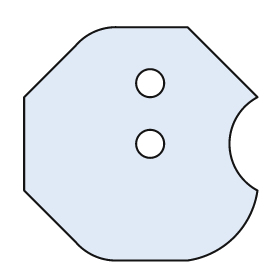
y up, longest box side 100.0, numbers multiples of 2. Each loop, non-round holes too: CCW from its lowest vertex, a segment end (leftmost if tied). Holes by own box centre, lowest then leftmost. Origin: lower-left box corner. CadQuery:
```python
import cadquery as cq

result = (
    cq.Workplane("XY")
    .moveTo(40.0, 0.0)
    .lineTo(70.0, 0.0)
    .threePointArc((90.0, 10.0), (100.0, 30.0))
    .threePointArc((88.0, 50.0), (100.0, 70.0))
    .lineTo(70.0, 100.0)
    .lineTo(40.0, 100.0)
    .threePointArc((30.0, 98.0), (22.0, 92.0))
    .lineTo(0.0, 70.0)
    .lineTo(0.0, 30.0)
    .lineTo(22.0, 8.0)
    .threePointArc((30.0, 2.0), (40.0, 0.0))
    .close()
    .moveTo(54.0, 50.0)
    .circle(6.0)
    .moveTo(54.0, 76.0)
    .circle(6.0)
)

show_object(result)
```